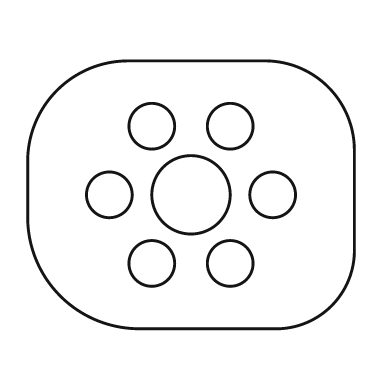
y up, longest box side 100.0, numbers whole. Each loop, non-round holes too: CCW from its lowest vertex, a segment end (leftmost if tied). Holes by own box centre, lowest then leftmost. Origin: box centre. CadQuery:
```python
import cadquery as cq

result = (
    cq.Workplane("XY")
    .moveTo(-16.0, -41.0)
    .lineTo(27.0, -41.0)
    .threePointArc((43.0, -34.0), (50.0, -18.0))
    .lineTo(50.0, 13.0)
    .threePointArc((42.0, 33.0), (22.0, 41.0))
    .lineTo(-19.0, 41.0)
    .threePointArc((-41.0, 32.0), (-50.0, 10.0))
    .lineTo(-50.0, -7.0)
    .threePointArc((-40.0, -31.0), (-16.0, -41.0))
    .close()
    .moveTo(-12.0, -21.0)
    .circle(7.0)
    .moveTo(12.0, -21.0)
    .circle(7.0)
    .moveTo(-25.0, 0.0)
    .circle(7.0)
    .moveTo(0.0, 0.0)
    .circle(12.0)
    .moveTo(25.0, 0.0)
    .circle(7.0)
    .moveTo(-12.0, 21.0)
    .circle(7.0)
    .moveTo(12.0, 21.0)
    .circle(7.0)
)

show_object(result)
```